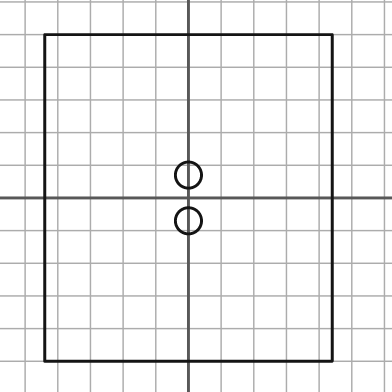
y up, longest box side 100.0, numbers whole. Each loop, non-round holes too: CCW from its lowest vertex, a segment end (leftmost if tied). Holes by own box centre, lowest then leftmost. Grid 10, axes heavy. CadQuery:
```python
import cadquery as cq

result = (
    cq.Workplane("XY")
    .moveTo(-44.0, -50.0)
    .lineTo(44.0, -50.0)
    .lineTo(44.0, 50.0)
    .lineTo(-44.0, 50.0)
    .close()
    .moveTo(0.0, -7.0)
    .circle(4.0)
    .moveTo(0.0, 7.0)
    .circle(4.0)
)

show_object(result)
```